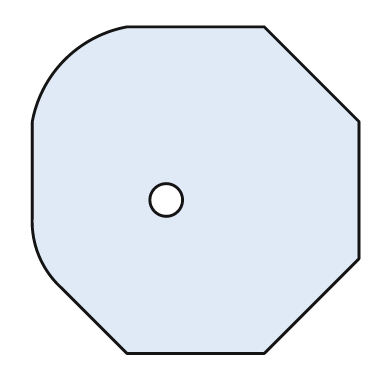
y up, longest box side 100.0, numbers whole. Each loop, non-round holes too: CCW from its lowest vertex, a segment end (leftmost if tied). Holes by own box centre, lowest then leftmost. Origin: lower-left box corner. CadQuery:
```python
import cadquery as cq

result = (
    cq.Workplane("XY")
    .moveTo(29.0, 0.0)
    .lineTo(71.0, 0.0)
    .lineTo(100.0, 29.0)
    .lineTo(100.0, 71.0)
    .lineTo(71.0, 100.0)
    .lineTo(29.0, 100.0)
    .threePointArc((10.0, 90.0), (0.0, 71.0))
    .lineTo(0.0, 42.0)
    .threePointArc((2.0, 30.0), (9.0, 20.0))
    .close()
    .moveTo(41.0, 47.0)
    .circle(5.0)
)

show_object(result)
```